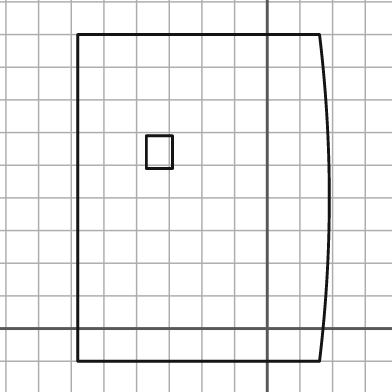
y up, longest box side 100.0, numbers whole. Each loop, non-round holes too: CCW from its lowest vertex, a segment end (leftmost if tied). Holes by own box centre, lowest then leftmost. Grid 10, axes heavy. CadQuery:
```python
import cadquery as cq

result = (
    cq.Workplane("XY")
    .moveTo(-58.0, -10.0)
    .lineTo(16.0, -10.0)
    .threePointArc((19.0, 40.0), (16.0, 90.0))
    .lineTo(-58.0, 90.0)
    .close()
    .moveTo(-37.0, 49.0)
    .lineTo(-29.0, 49.0)
    .lineTo(-29.0, 59.0)
    .lineTo(-37.0, 59.0)
    .close()
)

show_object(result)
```